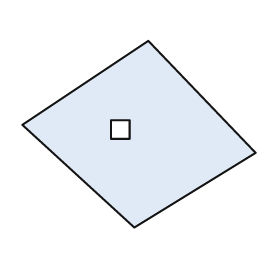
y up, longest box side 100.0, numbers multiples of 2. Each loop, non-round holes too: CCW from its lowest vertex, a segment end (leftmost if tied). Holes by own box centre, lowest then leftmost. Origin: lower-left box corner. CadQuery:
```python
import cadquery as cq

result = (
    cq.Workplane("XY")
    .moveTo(48.0, 0.0)
    .lineTo(100.0, 32.0)
    .lineTo(54.0, 80.0)
    .lineTo(0.0, 44.0)
    .close()
    .moveTo(38.0, 38.0)
    .lineTo(46.0, 38.0)
    .lineTo(46.0, 46.0)
    .lineTo(38.0, 46.0)
    .close()
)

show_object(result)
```